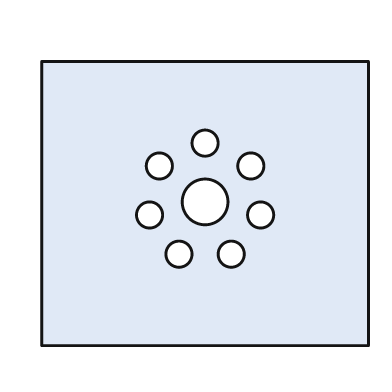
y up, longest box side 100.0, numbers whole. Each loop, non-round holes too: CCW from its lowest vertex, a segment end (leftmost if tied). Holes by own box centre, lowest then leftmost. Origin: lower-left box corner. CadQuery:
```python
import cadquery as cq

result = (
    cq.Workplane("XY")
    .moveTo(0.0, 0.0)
    .lineTo(100.0, 0.0)
    .lineTo(100.0, 87.0)
    .lineTo(0.0, 87.0)
    .close()
    .moveTo(42.0, 28.0)
    .circle(4.0)
    .moveTo(58.0, 28.0)
    .circle(4.0)
    .moveTo(33.0, 40.0)
    .circle(4.0)
    .moveTo(67.0, 40.0)
    .circle(4.0)
    .moveTo(50.0, 44.0)
    .circle(7.0)
    .moveTo(36.0, 55.0)
    .circle(4.0)
    .moveTo(64.0, 55.0)
    .circle(4.0)
    .moveTo(50.0, 62.0)
    .circle(4.0)
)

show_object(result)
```